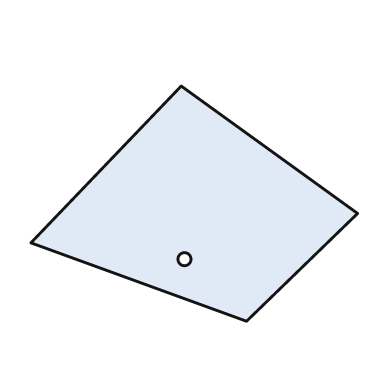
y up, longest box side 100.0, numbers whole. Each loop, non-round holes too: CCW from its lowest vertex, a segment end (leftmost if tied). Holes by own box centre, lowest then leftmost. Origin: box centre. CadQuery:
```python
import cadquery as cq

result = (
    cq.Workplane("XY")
    .moveTo(16.0, -36.0)
    .lineTo(50.0, -3.0)
    .lineTo(-4.0, 36.0)
    .lineTo(-50.0, -12.0)
    .close()
    .moveTo(-3.0, -17.0)
    .circle(2.0)
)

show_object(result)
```